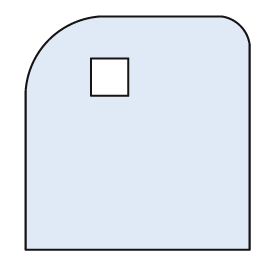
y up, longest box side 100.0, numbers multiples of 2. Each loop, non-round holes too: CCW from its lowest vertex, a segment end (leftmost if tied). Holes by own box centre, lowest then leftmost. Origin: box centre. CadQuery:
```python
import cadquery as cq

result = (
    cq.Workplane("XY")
    .moveTo(-48.0, -50.0)
    .lineTo(48.0, -50.0)
    .lineTo(48.0, 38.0)
    .threePointArc((44.0, 46.0), (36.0, 50.0))
    .lineTo(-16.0, 50.0)
    .threePointArc((-38.0, 40.0), (-48.0, 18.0))
    .close()
    .moveTo(-20.0, 16.0)
    .lineTo(-4.0, 16.0)
    .lineTo(-4.0, 32.0)
    .lineTo(-20.0, 32.0)
    .close()
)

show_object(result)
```